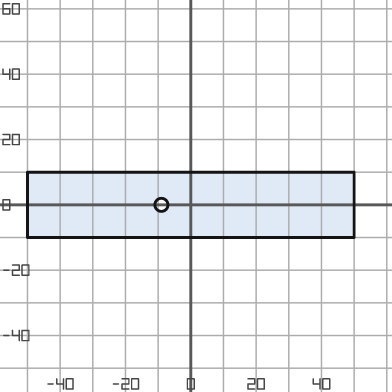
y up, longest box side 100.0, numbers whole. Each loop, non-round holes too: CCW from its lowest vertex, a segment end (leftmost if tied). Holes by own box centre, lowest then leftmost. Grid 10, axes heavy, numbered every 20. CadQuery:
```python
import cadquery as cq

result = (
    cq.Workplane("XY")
    .moveTo(-50.0, -10.0)
    .lineTo(50.0, -10.0)
    .lineTo(50.0, 10.0)
    .lineTo(-50.0, 10.0)
    .close()
    .moveTo(-9.0, 0.0)
    .circle(2.0)
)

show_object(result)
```